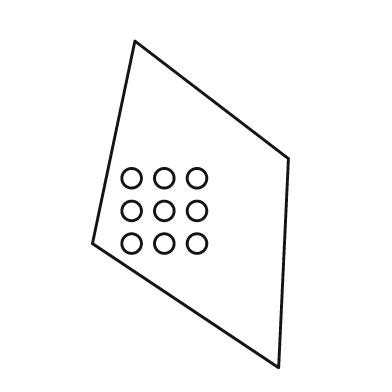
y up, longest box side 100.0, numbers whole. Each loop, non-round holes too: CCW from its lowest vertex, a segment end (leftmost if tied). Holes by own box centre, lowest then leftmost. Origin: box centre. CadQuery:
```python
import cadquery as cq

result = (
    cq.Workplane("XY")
    .moveTo(27.0, -50.0)
    .lineTo(30.0, 14.0)
    .lineTo(-17.0, 50.0)
    .lineTo(-30.0, -12.0)
    .close()
    .moveTo(-18.0, -12.0)
    .circle(3.0)
    .moveTo(-8.0, -12.0)
    .circle(3.0)
    .moveTo(2.0, -12.0)
    .circle(3.0)
    .moveTo(-18.0, -2.0)
    .circle(3.0)
    .moveTo(-8.0, -2.0)
    .circle(3.0)
    .moveTo(2.0, -2.0)
    .circle(3.0)
    .moveTo(-18.0, 8.0)
    .circle(3.0)
    .moveTo(-8.0, 8.0)
    .circle(3.0)
    .moveTo(2.0, 8.0)
    .circle(3.0)
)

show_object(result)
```